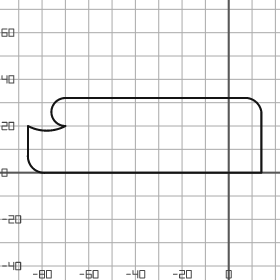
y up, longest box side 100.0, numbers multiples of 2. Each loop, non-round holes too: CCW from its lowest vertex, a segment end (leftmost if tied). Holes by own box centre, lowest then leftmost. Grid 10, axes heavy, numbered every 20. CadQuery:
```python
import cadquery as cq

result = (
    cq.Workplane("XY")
    .moveTo(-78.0, 0.0)
    .lineTo(14.0, 0.0)
    .lineTo(14.0, 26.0)
    .threePointArc((12.0, 30.0), (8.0, 32.0))
    .lineTo(-70.0, 32.0)
    .threePointArc((-76.0, 26.0), (-70.0, 20.0))
    .threePointArc((-78.0, 18.0), (-86.0, 20.0))
    .lineTo(-86.0, 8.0)
    .threePointArc((-84.0, 2.0), (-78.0, 0.0))
    .close()
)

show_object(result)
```